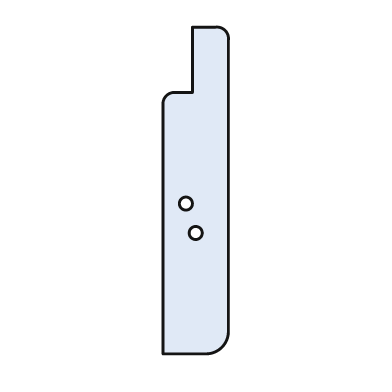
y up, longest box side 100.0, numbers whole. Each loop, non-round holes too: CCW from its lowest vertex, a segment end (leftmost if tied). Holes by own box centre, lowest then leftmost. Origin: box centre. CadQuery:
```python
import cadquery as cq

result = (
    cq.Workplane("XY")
    .moveTo(-10.0, -50.0)
    .lineTo(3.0, -50.0)
    .threePointArc((8.0, -48.0), (10.0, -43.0))
    .lineTo(10.0, 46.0)
    .threePointArc((9.0, 49.0), (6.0, 50.0))
    .lineTo(-1.0, 50.0)
    .lineTo(-1.0, 30.0)
    .lineTo(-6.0, 30.0)
    .threePointArc((-9.0, 29.0), (-10.0, 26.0))
    .close()
    .moveTo(0.0, -13.0)
    .circle(2.0)
    .moveTo(-3.0, -4.0)
    .circle(2.0)
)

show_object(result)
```